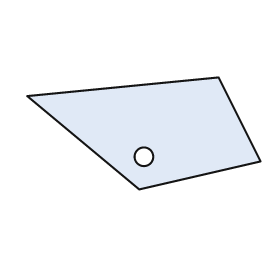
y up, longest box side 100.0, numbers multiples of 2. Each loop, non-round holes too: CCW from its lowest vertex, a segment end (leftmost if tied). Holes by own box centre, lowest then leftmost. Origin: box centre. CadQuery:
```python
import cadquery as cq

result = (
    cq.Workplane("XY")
    .moveTo(-2.0, -24.0)
    .lineTo(50.0, -12.0)
    .lineTo(32.0, 24.0)
    .lineTo(-50.0, 16.0)
    .close()
    .moveTo(0.0, -10.0)
    .circle(4.0)
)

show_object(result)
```